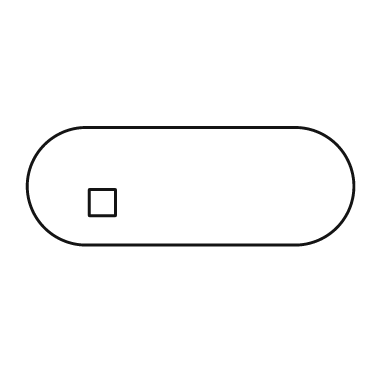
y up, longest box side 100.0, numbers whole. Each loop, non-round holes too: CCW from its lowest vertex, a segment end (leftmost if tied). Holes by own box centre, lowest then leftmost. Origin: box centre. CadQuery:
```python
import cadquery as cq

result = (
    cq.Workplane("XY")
    .moveTo(-32.0, -18.0)
    .lineTo(32.0, -18.0)
    .threePointArc((50.0, 0.0), (32.0, 18.0))
    .lineTo(-32.0, 18.0)
    .threePointArc((-50.0, 0.0), (-32.0, -18.0))
    .close()
    .moveTo(-31.0, -9.0)
    .lineTo(-23.0, -9.0)
    .lineTo(-23.0, -1.0)
    .lineTo(-31.0, -1.0)
    .close()
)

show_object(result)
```